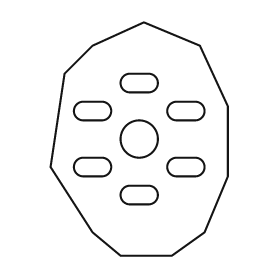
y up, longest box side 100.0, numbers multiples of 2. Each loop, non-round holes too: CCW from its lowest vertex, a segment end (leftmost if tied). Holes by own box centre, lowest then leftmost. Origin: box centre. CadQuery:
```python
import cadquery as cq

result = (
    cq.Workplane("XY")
    .moveTo(-8.0, -50.0)
    .lineTo(14.0, -50.0)
    .lineTo(28.0, -40.0)
    .lineTo(38.0, -16.0)
    .lineTo(38.0, 14.0)
    .lineTo(26.0, 40.0)
    .lineTo(2.0, 50.0)
    .lineTo(-20.0, 40.0)
    .lineTo(-32.0, 28.0)
    .lineTo(-38.0, -12.0)
    .lineTo(-20.0, -40.0)
    .close()
    .moveTo(-4.0, -28.0)
    .lineTo(4.0, -28.0)
    .threePointArc((8.0, -24.0), (4.0, -20.0))
    .lineTo(-4.0, -20.0)
    .threePointArc((-8.0, -24.0), (-4.0, -28.0))
    .close()
    .moveTo(-24.0, -16.0)
    .lineTo(-16.0, -16.0)
    .threePointArc((-12.0, -12.0), (-16.0, -8.0))
    .lineTo(-24.0, -8.0)
    .threePointArc((-28.0, -12.0), (-24.0, -16.0))
    .close()
    .moveTo(16.0, -16.0)
    .lineTo(24.0, -16.0)
    .threePointArc((28.0, -12.0), (24.0, -8.0))
    .lineTo(16.0, -8.0)
    .threePointArc((12.0, -12.0), (16.0, -16.0))
    .close()
    .moveTo(0.0, 0.0)
    .circle(8.0)
    .moveTo(-24.0, 8.0)
    .lineTo(-16.0, 8.0)
    .threePointArc((-12.0, 12.0), (-16.0, 16.0))
    .lineTo(-24.0, 16.0)
    .threePointArc((-28.0, 12.0), (-24.0, 8.0))
    .close()
    .moveTo(16.0, 8.0)
    .lineTo(24.0, 8.0)
    .threePointArc((28.0, 12.0), (24.0, 16.0))
    .lineTo(16.0, 16.0)
    .threePointArc((12.0, 12.0), (16.0, 8.0))
    .close()
    .moveTo(-4.0, 20.0)
    .lineTo(4.0, 20.0)
    .threePointArc((8.0, 24.0), (4.0, 28.0))
    .lineTo(-4.0, 28.0)
    .threePointArc((-8.0, 24.0), (-4.0, 20.0))
    .close()
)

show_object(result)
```